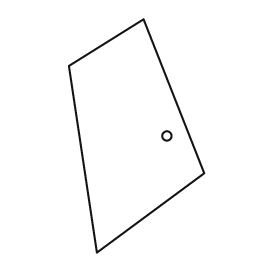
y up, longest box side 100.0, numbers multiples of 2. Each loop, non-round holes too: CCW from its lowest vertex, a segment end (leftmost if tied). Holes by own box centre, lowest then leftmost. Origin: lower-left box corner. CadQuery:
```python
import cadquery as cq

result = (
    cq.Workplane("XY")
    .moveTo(12.0, 0.0)
    .lineTo(58.0, 34.0)
    .lineTo(32.0, 100.0)
    .lineTo(0.0, 80.0)
    .close()
    .moveTo(42.0, 50.0)
    .circle(2.0)
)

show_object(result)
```